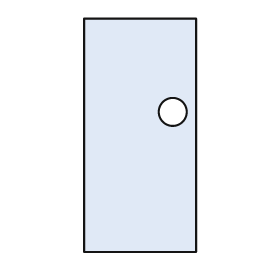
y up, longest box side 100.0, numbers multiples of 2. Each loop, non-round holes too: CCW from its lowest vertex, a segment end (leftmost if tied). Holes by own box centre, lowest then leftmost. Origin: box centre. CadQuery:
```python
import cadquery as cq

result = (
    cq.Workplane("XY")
    .moveTo(-24.0, -50.0)
    .lineTo(24.0, -50.0)
    .lineTo(24.0, 50.0)
    .lineTo(-24.0, 50.0)
    .close()
    .moveTo(14.0, 10.0)
    .circle(6.0)
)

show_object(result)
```